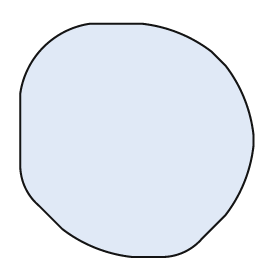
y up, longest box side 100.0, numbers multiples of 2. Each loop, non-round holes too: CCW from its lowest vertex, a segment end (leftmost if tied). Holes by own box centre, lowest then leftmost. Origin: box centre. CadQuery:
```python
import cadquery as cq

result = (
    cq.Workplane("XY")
    .moveTo(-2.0, -50.0)
    .lineTo(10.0, -50.0)
    .threePointArc((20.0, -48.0), (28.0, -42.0))
    .lineTo(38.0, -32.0)
    .threePointArc((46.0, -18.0), (50.0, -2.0))
    .lineTo(50.0, 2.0)
    .threePointArc((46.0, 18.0), (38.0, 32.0))
    .lineTo(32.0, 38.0)
    .threePointArc((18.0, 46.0), (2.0, 50.0))
    .lineTo(-20.0, 50.0)
    .threePointArc((-40.0, 40.0), (-50.0, 20.0))
    .lineTo(-50.0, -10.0)
    .threePointArc((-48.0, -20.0), (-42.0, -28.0))
    .lineTo(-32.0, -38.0)
    .threePointArc((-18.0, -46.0), (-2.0, -50.0))
    .close()
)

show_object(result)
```